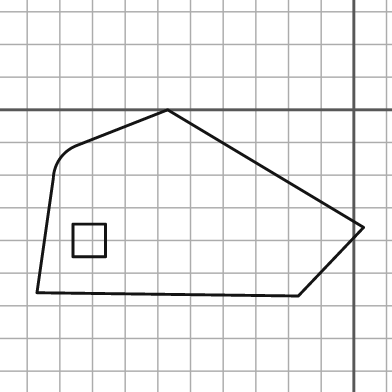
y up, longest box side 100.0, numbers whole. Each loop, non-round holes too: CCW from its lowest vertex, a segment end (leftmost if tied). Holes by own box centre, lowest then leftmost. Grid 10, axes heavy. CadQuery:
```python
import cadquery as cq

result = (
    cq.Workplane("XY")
    .moveTo(-17.0, -57.0)
    .lineTo(3.0, -36.0)
    .lineTo(-57.0, 0.0)
    .lineTo(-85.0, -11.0)
    .threePointArc((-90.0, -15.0), (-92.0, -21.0))
    .lineTo(-97.0, -56.0)
    .close()
    .moveTo(-86.0, -45.0)
    .lineTo(-76.0, -45.0)
    .lineTo(-76.0, -35.0)
    .lineTo(-86.0, -35.0)
    .close()
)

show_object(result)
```